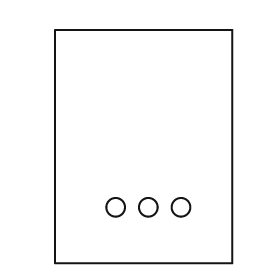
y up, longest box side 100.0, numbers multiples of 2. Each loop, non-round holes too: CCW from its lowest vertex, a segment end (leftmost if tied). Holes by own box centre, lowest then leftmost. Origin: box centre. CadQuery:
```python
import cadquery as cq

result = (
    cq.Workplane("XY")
    .moveTo(-38.0, -50.0)
    .lineTo(38.0, -50.0)
    .lineTo(38.0, 50.0)
    .lineTo(-38.0, 50.0)
    .close()
    .moveTo(-12.0, -26.0)
    .circle(4.0)
    .moveTo(2.0, -26.0)
    .circle(4.0)
    .moveTo(16.0, -26.0)
    .circle(4.0)
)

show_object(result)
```